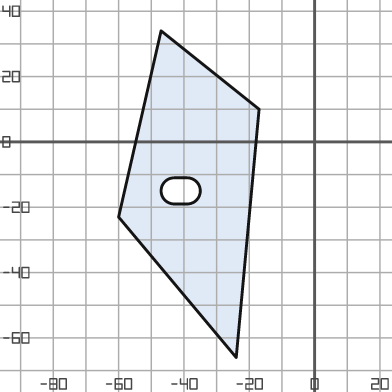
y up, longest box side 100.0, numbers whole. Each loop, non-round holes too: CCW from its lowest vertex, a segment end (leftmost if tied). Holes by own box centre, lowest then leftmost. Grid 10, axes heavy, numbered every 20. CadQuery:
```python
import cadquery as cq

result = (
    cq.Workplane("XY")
    .moveTo(-24.0, -66.0)
    .lineTo(-17.0, 10.0)
    .lineTo(-47.0, 34.0)
    .lineTo(-60.0, -23.0)
    .close()
    .moveTo(-43.0, -19.0)
    .lineTo(-39.0, -19.0)
    .threePointArc((-35.0, -15.0), (-39.0, -11.0))
    .lineTo(-43.0, -11.0)
    .threePointArc((-47.0, -15.0), (-43.0, -19.0))
    .close()
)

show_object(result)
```